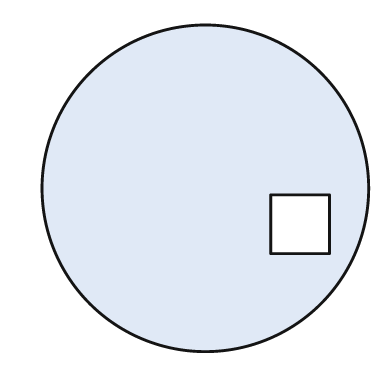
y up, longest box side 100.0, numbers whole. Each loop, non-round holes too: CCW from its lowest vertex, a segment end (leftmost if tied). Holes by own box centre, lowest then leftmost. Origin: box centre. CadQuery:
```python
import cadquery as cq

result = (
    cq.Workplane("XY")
    .moveTo(0.0, 0.0)
    .circle(50.0)
    .moveTo(20.0, -20.0)
    .lineTo(38.0, -20.0)
    .lineTo(38.0, -2.0)
    .lineTo(20.0, -2.0)
    .close()
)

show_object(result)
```